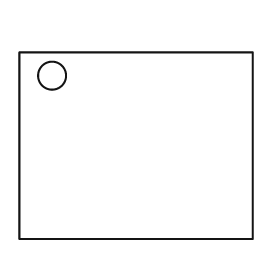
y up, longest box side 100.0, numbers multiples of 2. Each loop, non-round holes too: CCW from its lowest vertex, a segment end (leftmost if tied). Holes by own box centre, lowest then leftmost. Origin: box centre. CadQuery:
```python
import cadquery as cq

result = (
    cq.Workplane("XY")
    .moveTo(-50.0, -40.0)
    .lineTo(50.0, -40.0)
    .lineTo(50.0, 40.0)
    .lineTo(-50.0, 40.0)
    .close()
    .moveTo(-36.0, 30.0)
    .circle(6.0)
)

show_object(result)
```